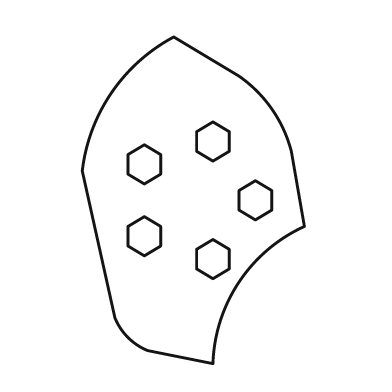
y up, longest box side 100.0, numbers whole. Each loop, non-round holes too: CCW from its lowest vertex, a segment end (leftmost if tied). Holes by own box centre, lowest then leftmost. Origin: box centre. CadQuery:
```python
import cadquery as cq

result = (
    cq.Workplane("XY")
    .moveTo(6.0, -50.0)
    .threePointArc((14.0, -25.0), (34.0, -8.0))
    .lineTo(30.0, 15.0)
    .threePointArc((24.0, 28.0), (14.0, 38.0))
    .lineTo(-6.0, 50.0)
    .threePointArc((-25.0, 33.0), (-34.0, 9.0))
    .lineTo(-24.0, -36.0)
    .threePointArc((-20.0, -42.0), (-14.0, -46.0))
    .close()
    .moveTo(6.0, -24.0)
    .lineTo(11.0, -21.0)
    .lineTo(11.0, -15.0)
    .lineTo(6.0, -12.0)
    .lineTo(1.0, -15.0)
    .lineTo(1.0, -21.0)
    .close()
    .moveTo(-15.0, -17.0)
    .lineTo(-10.0, -14.0)
    .lineTo(-10.0, -8.0)
    .lineTo(-15.0, -5.0)
    .lineTo(-20.0, -8.0)
    .lineTo(-20.0, -14.0)
    .close()
    .moveTo(19.0, -6.0)
    .lineTo(24.0, -3.0)
    .lineTo(24.0, 3.0)
    .lineTo(19.0, 6.0)
    .lineTo(14.0, 3.0)
    .lineTo(14.0, -3.0)
    .close()
    .moveTo(-15.0, 5.0)
    .lineTo(-10.0, 8.0)
    .lineTo(-10.0, 14.0)
    .lineTo(-15.0, 17.0)
    .lineTo(-20.0, 14.0)
    .lineTo(-20.0, 8.0)
    .close()
    .moveTo(6.0, 12.0)
    .lineTo(11.0, 15.0)
    .lineTo(11.0, 21.0)
    .lineTo(6.0, 24.0)
    .lineTo(1.0, 21.0)
    .lineTo(1.0, 15.0)
    .close()
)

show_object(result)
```